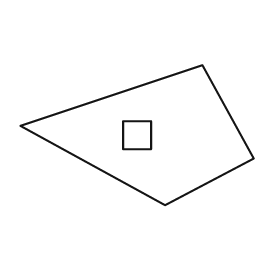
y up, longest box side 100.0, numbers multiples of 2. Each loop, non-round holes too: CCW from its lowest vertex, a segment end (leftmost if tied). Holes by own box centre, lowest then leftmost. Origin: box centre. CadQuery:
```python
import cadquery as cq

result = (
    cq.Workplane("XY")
    .moveTo(12.0, -30.0)
    .lineTo(50.0, -10.0)
    .lineTo(28.0, 30.0)
    .lineTo(-50.0, 4.0)
    .close()
    .moveTo(-6.0, -6.0)
    .lineTo(6.0, -6.0)
    .lineTo(6.0, 6.0)
    .lineTo(-6.0, 6.0)
    .close()
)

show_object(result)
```